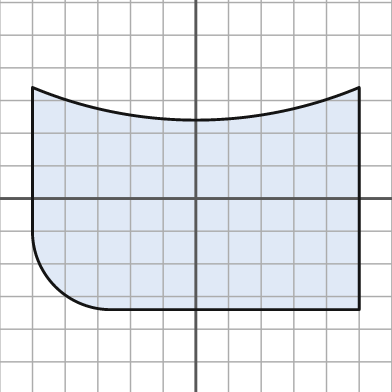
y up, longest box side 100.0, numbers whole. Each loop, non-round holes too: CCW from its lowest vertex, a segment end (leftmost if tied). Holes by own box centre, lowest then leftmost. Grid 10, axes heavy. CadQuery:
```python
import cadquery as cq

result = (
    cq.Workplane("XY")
    .moveTo(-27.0, -34.0)
    .lineTo(50.0, -34.0)
    .lineTo(50.0, 34.0)
    .threePointArc((0.0, 24.0), (-50.0, 34.0))
    .lineTo(-50.0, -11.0)
    .threePointArc((-43.0, -27.0), (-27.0, -34.0))
    .close()
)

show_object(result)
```